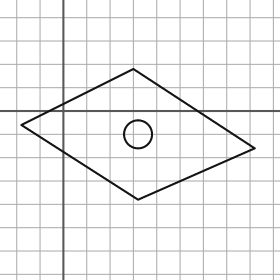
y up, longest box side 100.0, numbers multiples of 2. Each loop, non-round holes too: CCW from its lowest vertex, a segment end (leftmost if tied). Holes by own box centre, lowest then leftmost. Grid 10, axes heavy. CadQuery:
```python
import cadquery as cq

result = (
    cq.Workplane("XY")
    .moveTo(32.0, -38.0)
    .lineTo(82.0, -16.0)
    .lineTo(30.0, 18.0)
    .lineTo(-18.0, -6.0)
    .close()
    .moveTo(32.0, -10.0)
    .circle(6.0)
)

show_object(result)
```